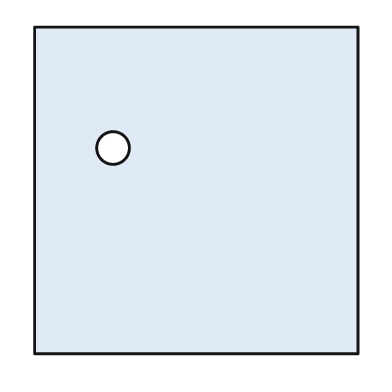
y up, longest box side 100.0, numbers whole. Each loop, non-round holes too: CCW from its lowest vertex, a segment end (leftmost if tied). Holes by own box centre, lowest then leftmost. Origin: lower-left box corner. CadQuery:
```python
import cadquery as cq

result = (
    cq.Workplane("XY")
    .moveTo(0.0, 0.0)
    .lineTo(99.0, 0.0)
    .lineTo(99.0, 100.0)
    .lineTo(0.0, 100.0)
    .close()
    .moveTo(24.0, 63.0)
    .circle(5.0)
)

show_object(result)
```